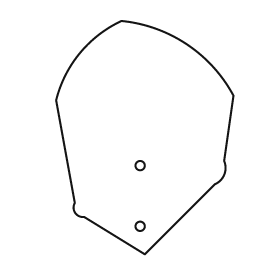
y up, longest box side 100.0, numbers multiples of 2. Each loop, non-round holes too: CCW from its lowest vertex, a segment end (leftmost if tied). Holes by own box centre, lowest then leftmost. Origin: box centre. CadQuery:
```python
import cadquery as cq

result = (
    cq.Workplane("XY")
    .moveTo(0.0, -50.0)
    .lineTo(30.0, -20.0)
    .threePointArc((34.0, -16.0), (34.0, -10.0))
    .lineTo(38.0, 18.0)
    .threePointArc((18.0, 40.0), (-10.0, 50.0))
    .threePointArc((-28.0, 36.0), (-38.0, 16.0))
    .lineTo(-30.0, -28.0)
    .threePointArc((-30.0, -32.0), (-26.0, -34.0))
    .close()
    .moveTo(-2.0, -38.0)
    .circle(2.0)
    .moveTo(-2.0, -12.0)
    .circle(2.0)
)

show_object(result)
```